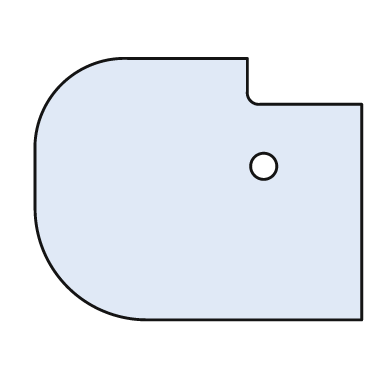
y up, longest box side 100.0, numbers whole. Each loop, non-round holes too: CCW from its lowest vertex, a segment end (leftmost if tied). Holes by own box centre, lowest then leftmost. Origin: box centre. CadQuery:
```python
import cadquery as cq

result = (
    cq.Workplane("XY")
    .moveTo(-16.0, -40.0)
    .lineTo(50.0, -40.0)
    .lineTo(50.0, 26.0)
    .lineTo(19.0, 26.0)
    .threePointArc((16.0, 27.0), (15.0, 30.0))
    .lineTo(15.0, 40.0)
    .lineTo(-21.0, 40.0)
    .threePointArc((-42.0, 32.0), (-50.0, 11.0))
    .lineTo(-50.0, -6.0)
    .threePointArc((-40.0, -30.0), (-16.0, -40.0))
    .close()
    .moveTo(20.0, 7.0)
    .circle(4.0)
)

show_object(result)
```